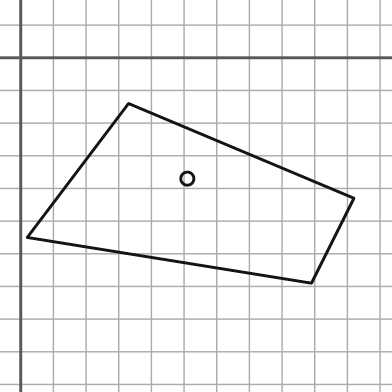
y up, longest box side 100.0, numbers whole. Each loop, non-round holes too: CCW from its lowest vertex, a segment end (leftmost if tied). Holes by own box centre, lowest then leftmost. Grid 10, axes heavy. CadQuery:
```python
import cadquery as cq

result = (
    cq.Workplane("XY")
    .moveTo(89.0, -69.0)
    .lineTo(102.0, -43.0)
    .lineTo(33.0, -14.0)
    .lineTo(2.0, -55.0)
    .close()
    .moveTo(51.0, -37.0)
    .circle(2.0)
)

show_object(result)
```